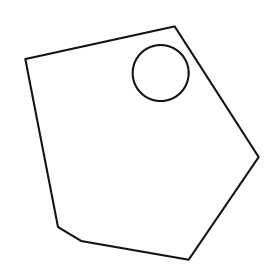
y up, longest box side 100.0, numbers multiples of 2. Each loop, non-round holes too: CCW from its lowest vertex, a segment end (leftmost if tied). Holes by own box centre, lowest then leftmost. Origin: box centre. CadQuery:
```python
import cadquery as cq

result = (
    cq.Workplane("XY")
    .moveTo(20.0, -50.0)
    .lineTo(50.0, -6.0)
    .lineTo(14.0, 50.0)
    .lineTo(-50.0, 36.0)
    .lineTo(-36.0, -36.0)
    .lineTo(-26.0, -42.0)
    .close()
    .moveTo(8.0, 30.0)
    .circle(12.0)
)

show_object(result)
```